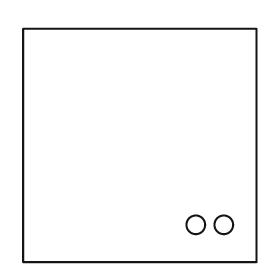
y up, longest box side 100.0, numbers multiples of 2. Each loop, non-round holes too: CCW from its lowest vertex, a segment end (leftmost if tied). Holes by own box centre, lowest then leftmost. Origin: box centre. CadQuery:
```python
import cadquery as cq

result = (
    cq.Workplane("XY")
    .moveTo(-50.0, -50.0)
    .lineTo(50.0, -50.0)
    .lineTo(50.0, 50.0)
    .lineTo(-50.0, 50.0)
    .close()
    .moveTo(24.0, -34.0)
    .circle(4.0)
    .moveTo(36.0, -34.0)
    .circle(4.0)
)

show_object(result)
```